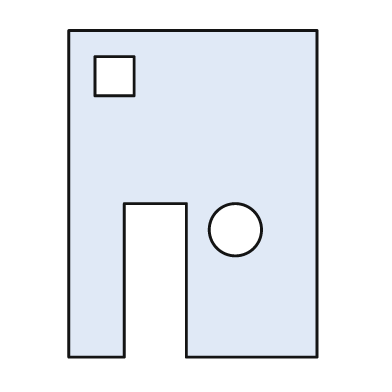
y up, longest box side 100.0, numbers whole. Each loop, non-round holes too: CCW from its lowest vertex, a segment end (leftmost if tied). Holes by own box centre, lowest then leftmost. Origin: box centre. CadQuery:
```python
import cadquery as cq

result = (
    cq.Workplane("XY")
    .moveTo(-38.0, -50.0)
    .lineTo(-21.0, -50.0)
    .lineTo(-21.0, -3.0)
    .lineTo(-2.0, -3.0)
    .lineTo(-2.0, -50.0)
    .lineTo(38.0, -50.0)
    .lineTo(38.0, 50.0)
    .lineTo(-38.0, 50.0)
    .close()
    .moveTo(13.0, -11.0)
    .circle(8.0)
    .moveTo(-30.0, 30.0)
    .lineTo(-18.0, 30.0)
    .lineTo(-18.0, 42.0)
    .lineTo(-30.0, 42.0)
    .close()
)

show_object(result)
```